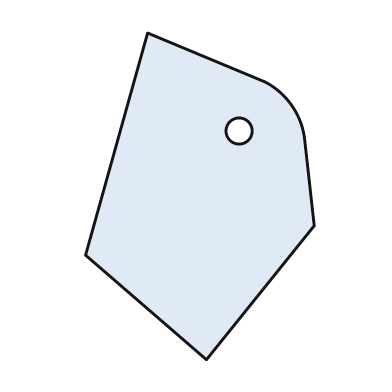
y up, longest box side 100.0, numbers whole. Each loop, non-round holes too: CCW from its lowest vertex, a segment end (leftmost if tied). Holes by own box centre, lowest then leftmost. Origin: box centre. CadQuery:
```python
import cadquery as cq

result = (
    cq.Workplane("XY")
    .moveTo(2.0, -50.0)
    .lineTo(35.0, -9.0)
    .lineTo(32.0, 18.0)
    .threePointArc((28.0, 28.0), (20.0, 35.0))
    .lineTo(-16.0, 50.0)
    .lineTo(-35.0, -18.0)
    .close()
    .moveTo(12.0, 20.0)
    .circle(4.0)
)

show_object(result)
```